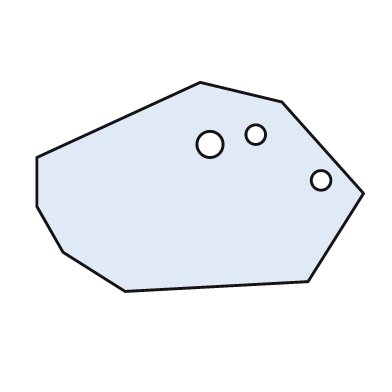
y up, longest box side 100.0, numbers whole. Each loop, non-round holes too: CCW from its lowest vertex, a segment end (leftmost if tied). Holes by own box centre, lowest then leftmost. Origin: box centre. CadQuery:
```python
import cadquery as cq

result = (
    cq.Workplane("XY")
    .moveTo(-23.0, -32.0)
    .lineTo(33.0, -29.0)
    .lineTo(50.0, -2.0)
    .lineTo(25.0, 26.0)
    .lineTo(0.0, 32.0)
    .lineTo(-50.0, 9.0)
    .lineTo(-50.0, -6.0)
    .lineTo(-42.0, -20.0)
    .close()
    .moveTo(37.0, 2.0)
    .circle(3.0)
    .moveTo(3.0, 13.0)
    .circle(4.0)
    .moveTo(17.0, 16.0)
    .circle(3.0)
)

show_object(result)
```